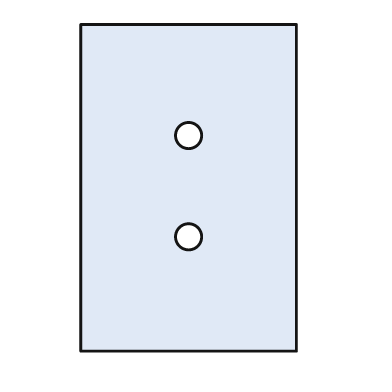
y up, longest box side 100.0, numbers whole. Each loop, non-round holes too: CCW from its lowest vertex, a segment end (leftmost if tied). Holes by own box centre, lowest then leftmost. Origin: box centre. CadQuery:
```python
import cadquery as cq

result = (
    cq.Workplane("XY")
    .moveTo(-33.0, -50.0)
    .lineTo(33.0, -50.0)
    .lineTo(33.0, 50.0)
    .lineTo(-33.0, 50.0)
    .close()
    .moveTo(0.0, -15.0)
    .circle(4.0)
    .moveTo(0.0, 16.0)
    .circle(4.0)
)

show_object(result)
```